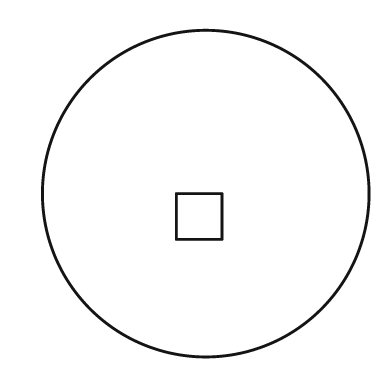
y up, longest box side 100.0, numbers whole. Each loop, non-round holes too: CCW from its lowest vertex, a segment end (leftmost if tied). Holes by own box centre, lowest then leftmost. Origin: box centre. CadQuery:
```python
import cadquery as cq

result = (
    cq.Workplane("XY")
    .moveTo(0.0, 0.0)
    .circle(50.0)
    .moveTo(-9.0, -14.0)
    .lineTo(5.0, -14.0)
    .lineTo(5.0, 0.0)
    .lineTo(-9.0, 0.0)
    .close()
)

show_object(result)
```